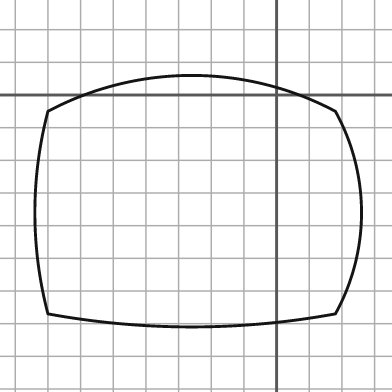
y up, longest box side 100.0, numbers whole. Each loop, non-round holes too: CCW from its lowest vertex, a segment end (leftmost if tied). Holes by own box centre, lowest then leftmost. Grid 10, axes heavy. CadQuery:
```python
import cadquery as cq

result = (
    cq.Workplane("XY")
    .moveTo(-70.0, -67.0)
    .threePointArc((-26.0, -71.0), (18.0, -67.0))
    .threePointArc((26.0, -36.0), (18.0, -5.0))
    .threePointArc((-26.0, 6.0), (-70.0, -5.0))
    .threePointArc((-74.0, -36.0), (-70.0, -67.0))
    .close()
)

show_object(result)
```